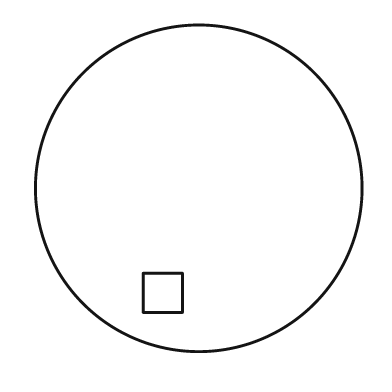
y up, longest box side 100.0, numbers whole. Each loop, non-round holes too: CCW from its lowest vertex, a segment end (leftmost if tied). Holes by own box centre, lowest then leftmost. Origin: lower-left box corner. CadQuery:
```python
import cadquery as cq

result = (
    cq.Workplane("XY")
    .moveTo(50.0, 50.0)
    .circle(50.0)
    .moveTo(33.0, 12.0)
    .lineTo(45.0, 12.0)
    .lineTo(45.0, 24.0)
    .lineTo(33.0, 24.0)
    .close()
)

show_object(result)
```